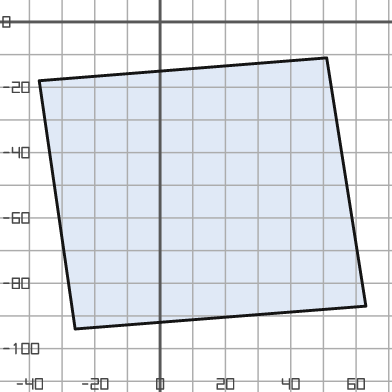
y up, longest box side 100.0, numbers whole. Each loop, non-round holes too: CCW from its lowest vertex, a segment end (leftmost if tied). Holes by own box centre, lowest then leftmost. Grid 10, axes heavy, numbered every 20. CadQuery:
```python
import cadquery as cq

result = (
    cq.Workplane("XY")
    .moveTo(-26.0, -94.0)
    .lineTo(63.0, -87.0)
    .lineTo(51.0, -11.0)
    .lineTo(-37.0, -18.0)
    .close()
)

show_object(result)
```